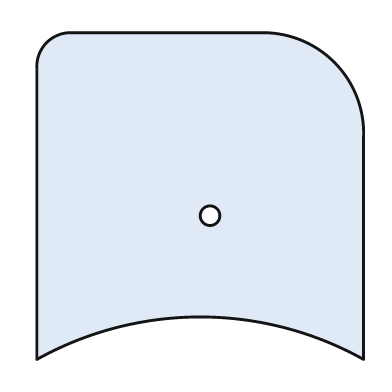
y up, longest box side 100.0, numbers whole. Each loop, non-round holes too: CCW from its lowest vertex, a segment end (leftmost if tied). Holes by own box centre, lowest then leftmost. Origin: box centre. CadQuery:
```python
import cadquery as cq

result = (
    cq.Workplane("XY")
    .moveTo(-50.0, -50.0)
    .threePointArc((0.0, -37.0), (50.0, -50.0))
    .lineTo(50.0, 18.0)
    .threePointArc((41.0, 41.0), (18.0, 50.0))
    .lineTo(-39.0, 50.0)
    .threePointArc((-47.0, 47.0), (-50.0, 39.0))
    .close()
    .moveTo(3.0, -6.0)
    .circle(3.0)
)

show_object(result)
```